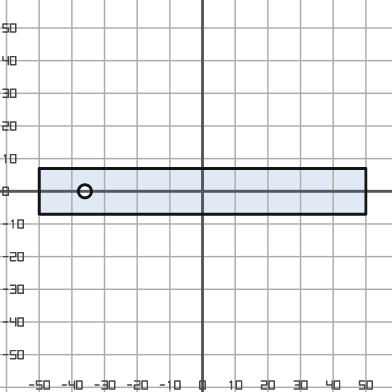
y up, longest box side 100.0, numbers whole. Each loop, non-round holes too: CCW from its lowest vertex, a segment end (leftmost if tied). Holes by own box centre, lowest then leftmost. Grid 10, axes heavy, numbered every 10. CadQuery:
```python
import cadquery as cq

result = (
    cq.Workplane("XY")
    .moveTo(-50.0, -7.0)
    .lineTo(50.0, -7.0)
    .lineTo(50.0, 7.0)
    .lineTo(-50.0, 7.0)
    .close()
    .moveTo(-36.0, 0.0)
    .circle(2.0)
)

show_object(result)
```